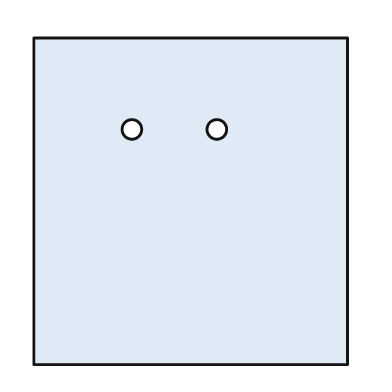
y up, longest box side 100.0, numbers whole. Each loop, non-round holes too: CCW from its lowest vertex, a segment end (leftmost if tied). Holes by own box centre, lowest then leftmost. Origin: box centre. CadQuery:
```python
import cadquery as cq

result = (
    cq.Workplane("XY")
    .moveTo(-48.0, -50.0)
    .lineTo(48.0, -50.0)
    .lineTo(48.0, 50.0)
    .lineTo(-48.0, 50.0)
    .close()
    .moveTo(-18.0, 22.0)
    .circle(3.0)
    .moveTo(8.0, 22.0)
    .circle(3.0)
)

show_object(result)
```